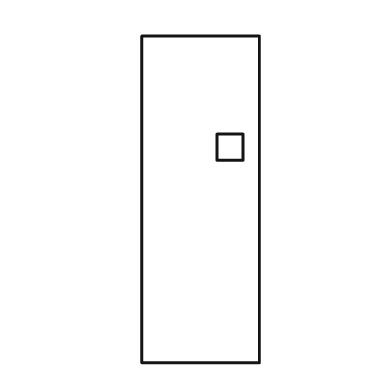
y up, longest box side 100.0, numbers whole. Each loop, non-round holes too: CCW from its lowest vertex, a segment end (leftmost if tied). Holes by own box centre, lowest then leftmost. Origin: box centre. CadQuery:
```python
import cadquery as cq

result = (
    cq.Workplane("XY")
    .moveTo(-18.0, -50.0)
    .lineTo(18.0, -50.0)
    .lineTo(18.0, 50.0)
    .lineTo(-18.0, 50.0)
    .close()
    .moveTo(5.0, 12.0)
    .lineTo(13.0, 12.0)
    .lineTo(13.0, 20.0)
    .lineTo(5.0, 20.0)
    .close()
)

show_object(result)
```